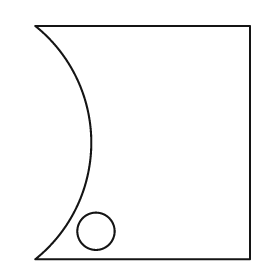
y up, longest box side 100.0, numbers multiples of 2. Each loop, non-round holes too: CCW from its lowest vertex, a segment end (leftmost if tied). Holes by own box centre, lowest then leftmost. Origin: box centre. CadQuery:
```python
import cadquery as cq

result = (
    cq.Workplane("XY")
    .moveTo(-46.0, -50.0)
    .lineTo(46.0, -50.0)
    .lineTo(46.0, 50.0)
    .lineTo(-46.0, 50.0)
    .threePointArc((-22.0, 0.0), (-46.0, -50.0))
    .close()
    .moveTo(-20.0, -38.0)
    .circle(8.0)
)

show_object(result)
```